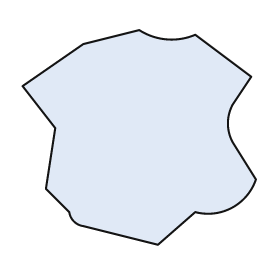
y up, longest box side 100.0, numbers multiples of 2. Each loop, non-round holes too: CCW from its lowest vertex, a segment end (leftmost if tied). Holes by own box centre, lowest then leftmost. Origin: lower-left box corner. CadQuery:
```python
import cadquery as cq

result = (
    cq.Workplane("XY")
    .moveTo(58.0, 0.0)
    .lineTo(74.0, 14.0)
    .threePointArc((90.0, 16.0), (100.0, 28.0))
    .lineTo(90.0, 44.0)
    .threePointArc((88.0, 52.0), (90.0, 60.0))
    .lineTo(98.0, 72.0)
    .lineTo(74.0, 90.0)
    .threePointArc((62.0, 88.0), (50.0, 92.0))
    .lineTo(26.0, 86.0)
    .lineTo(0.0, 68.0)
    .lineTo(14.0, 50.0)
    .lineTo(10.0, 24.0)
    .lineTo(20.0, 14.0)
    .threePointArc((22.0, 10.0), (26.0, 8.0))
    .close()
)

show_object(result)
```